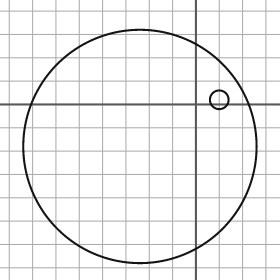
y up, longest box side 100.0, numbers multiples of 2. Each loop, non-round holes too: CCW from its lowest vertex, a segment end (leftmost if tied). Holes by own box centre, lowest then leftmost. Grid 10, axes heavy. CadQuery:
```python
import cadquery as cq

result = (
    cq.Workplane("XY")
    .moveTo(-24.0, -18.0)
    .circle(50.0)
    .moveTo(10.0, 2.0)
    .circle(4.0)
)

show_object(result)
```